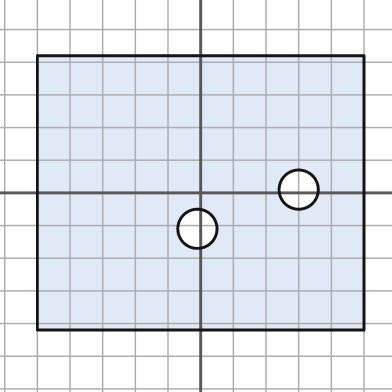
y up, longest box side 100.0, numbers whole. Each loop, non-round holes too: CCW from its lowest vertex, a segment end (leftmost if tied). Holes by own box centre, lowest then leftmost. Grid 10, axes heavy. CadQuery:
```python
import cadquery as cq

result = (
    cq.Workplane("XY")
    .moveTo(-50.0, -42.0)
    .lineTo(50.0, -42.0)
    .lineTo(50.0, 42.0)
    .lineTo(-50.0, 42.0)
    .close()
    .moveTo(-1.0, -11.0)
    .circle(6.0)
    .moveTo(30.0, 1.0)
    .circle(6.0)
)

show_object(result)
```